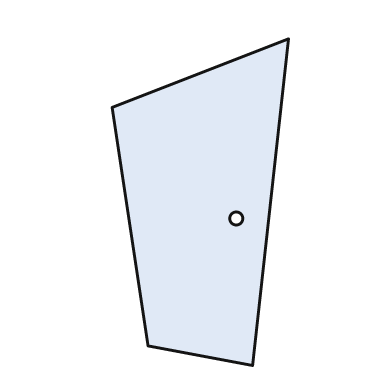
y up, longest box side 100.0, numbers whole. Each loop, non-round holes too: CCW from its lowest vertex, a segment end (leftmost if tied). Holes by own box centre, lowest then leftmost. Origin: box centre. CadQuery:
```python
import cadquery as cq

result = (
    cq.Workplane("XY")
    .moveTo(16.0, -50.0)
    .lineTo(27.0, 50.0)
    .lineTo(-27.0, 29.0)
    .lineTo(-16.0, -44.0)
    .close()
    .moveTo(11.0, -5.0)
    .circle(2.0)
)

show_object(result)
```